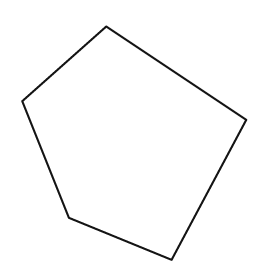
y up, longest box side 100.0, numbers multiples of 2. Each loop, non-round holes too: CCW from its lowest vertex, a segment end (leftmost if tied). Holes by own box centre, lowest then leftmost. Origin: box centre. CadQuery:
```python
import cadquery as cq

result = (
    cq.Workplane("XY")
    .moveTo(16.0, -50.0)
    .lineTo(48.0, 10.0)
    .lineTo(-12.0, 50.0)
    .lineTo(-48.0, 18.0)
    .lineTo(-28.0, -32.0)
    .close()
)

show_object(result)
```